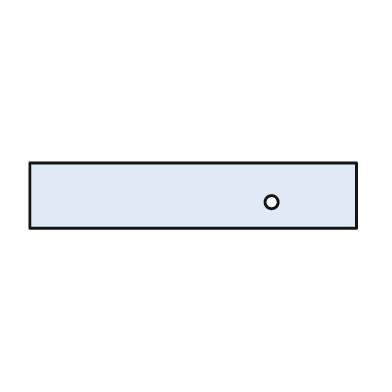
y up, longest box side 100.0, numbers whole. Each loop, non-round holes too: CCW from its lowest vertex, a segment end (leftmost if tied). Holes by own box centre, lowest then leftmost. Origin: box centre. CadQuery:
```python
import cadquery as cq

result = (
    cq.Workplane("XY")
    .moveTo(-50.0, -10.0)
    .lineTo(50.0, -10.0)
    .lineTo(50.0, 10.0)
    .lineTo(-50.0, 10.0)
    .close()
    .moveTo(24.0, -2.0)
    .circle(2.0)
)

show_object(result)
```